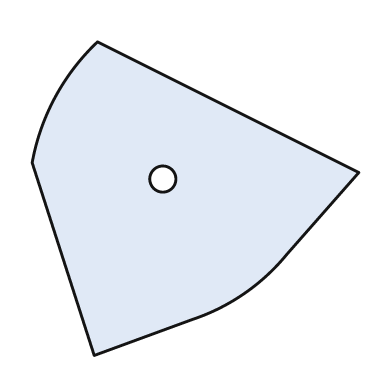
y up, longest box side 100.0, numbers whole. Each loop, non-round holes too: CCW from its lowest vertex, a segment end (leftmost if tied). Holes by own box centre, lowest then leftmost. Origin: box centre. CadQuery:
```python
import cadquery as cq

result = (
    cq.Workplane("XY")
    .moveTo(-31.0, -48.0)
    .lineTo(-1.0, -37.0)
    .threePointArc((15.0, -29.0), (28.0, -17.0))
    .lineTo(50.0, 8.0)
    .lineTo(-30.0, 48.0)
    .threePointArc((-43.0, 31.0), (-50.0, 11.0))
    .close()
    .moveTo(-10.0, 6.0)
    .circle(4.0)
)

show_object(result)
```